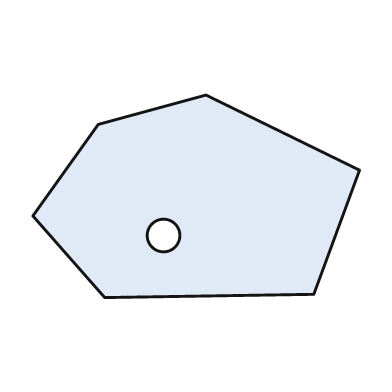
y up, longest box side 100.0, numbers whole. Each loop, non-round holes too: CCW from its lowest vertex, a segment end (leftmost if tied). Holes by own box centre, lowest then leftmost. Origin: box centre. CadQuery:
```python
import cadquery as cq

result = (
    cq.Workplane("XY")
    .moveTo(-28.0, -31.0)
    .lineTo(36.0, -30.0)
    .lineTo(50.0, 8.0)
    .lineTo(3.0, 31.0)
    .lineTo(-30.0, 22.0)
    .lineTo(-50.0, -6.0)
    .close()
    .moveTo(-10.0, -12.0)
    .circle(5.0)
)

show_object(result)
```